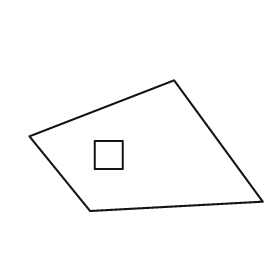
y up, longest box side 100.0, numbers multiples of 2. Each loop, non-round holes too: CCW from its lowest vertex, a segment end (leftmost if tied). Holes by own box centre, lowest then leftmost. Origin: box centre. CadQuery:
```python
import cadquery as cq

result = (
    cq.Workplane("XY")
    .moveTo(-24.0, -28.0)
    .lineTo(50.0, -24.0)
    .lineTo(12.0, 28.0)
    .lineTo(-50.0, 4.0)
    .close()
    .moveTo(-22.0, -10.0)
    .lineTo(-10.0, -10.0)
    .lineTo(-10.0, 2.0)
    .lineTo(-22.0, 2.0)
    .close()
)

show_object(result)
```